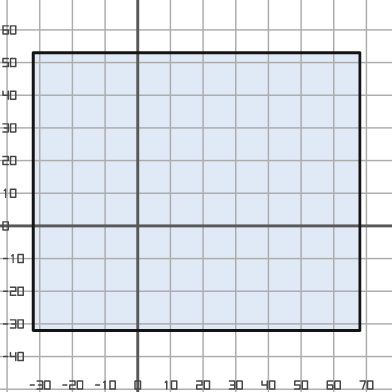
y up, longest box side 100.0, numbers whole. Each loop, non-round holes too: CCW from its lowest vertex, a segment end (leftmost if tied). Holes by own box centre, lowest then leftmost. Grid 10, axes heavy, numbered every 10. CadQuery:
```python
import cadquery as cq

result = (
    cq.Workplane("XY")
    .moveTo(-32.0, -32.0)
    .lineTo(68.0, -32.0)
    .lineTo(68.0, 53.0)
    .lineTo(-32.0, 53.0)
    .close()
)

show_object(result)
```